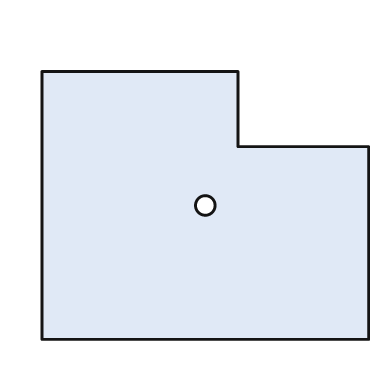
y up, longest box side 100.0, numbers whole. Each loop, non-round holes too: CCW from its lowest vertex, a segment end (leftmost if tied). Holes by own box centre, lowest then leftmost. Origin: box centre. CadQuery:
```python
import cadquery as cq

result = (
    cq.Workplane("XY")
    .moveTo(-50.0, -41.0)
    .lineTo(50.0, -41.0)
    .lineTo(50.0, 18.0)
    .lineTo(10.0, 18.0)
    .lineTo(10.0, 41.0)
    .lineTo(-50.0, 41.0)
    .close()
    .moveTo(0.0, 0.0)
    .circle(3.0)
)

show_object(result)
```